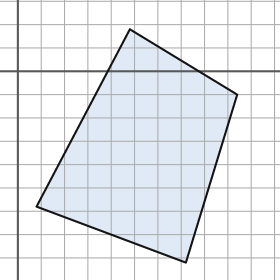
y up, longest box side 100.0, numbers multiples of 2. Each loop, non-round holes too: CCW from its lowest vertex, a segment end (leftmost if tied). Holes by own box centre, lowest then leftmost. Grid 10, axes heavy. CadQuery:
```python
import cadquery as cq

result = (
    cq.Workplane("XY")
    .moveTo(72.0, -82.0)
    .lineTo(94.0, -10.0)
    .lineTo(48.0, 18.0)
    .lineTo(8.0, -58.0)
    .close()
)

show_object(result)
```